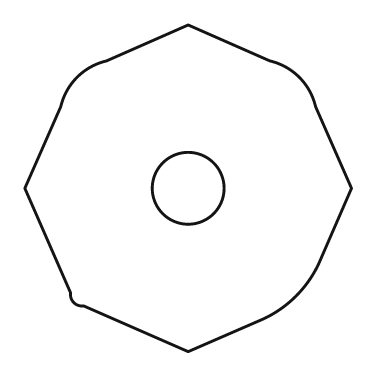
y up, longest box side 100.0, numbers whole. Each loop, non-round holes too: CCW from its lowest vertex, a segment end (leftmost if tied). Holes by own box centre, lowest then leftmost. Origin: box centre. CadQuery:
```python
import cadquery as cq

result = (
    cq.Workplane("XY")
    .moveTo(0.0, -50.0)
    .lineTo(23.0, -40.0)
    .threePointArc((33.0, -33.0), (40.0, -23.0))
    .lineTo(50.0, 0.0)
    .lineTo(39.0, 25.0)
    .threePointArc((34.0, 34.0), (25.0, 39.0))
    .lineTo(0.0, 50.0)
    .lineTo(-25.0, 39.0)
    .threePointArc((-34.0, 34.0), (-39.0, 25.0))
    .lineTo(-50.0, 0.0)
    .lineTo(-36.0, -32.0)
    .threePointArc((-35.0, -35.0), (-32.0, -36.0))
    .close()
    .moveTo(0.0, 0.0)
    .circle(11.0)
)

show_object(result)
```